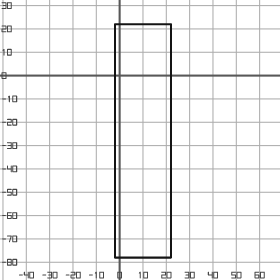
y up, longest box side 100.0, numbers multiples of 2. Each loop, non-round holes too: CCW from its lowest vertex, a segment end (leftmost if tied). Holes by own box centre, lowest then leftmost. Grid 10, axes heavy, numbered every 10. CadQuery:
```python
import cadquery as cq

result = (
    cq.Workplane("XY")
    .moveTo(-2.0, -78.0)
    .lineTo(22.0, -78.0)
    .lineTo(22.0, 22.0)
    .lineTo(-2.0, 22.0)
    .close()
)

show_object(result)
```